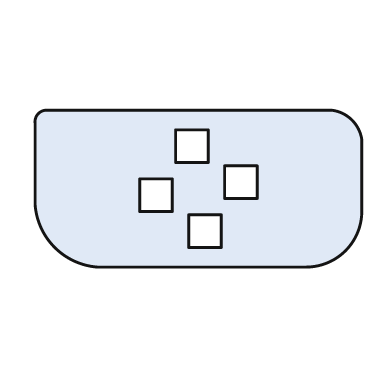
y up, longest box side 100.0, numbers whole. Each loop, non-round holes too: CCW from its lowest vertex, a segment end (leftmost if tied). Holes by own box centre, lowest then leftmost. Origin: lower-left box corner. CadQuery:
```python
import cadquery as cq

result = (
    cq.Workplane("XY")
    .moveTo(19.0, 0.0)
    .lineTo(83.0, 0.0)
    .threePointArc((95.0, 5.0), (100.0, 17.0))
    .lineTo(100.0, 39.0)
    .threePointArc((97.0, 45.0), (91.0, 48.0))
    .lineTo(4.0, 48.0)
    .threePointArc((1.0, 47.0), (0.0, 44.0))
    .lineTo(0.0, 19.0)
    .threePointArc((6.0, 6.0), (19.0, 0.0))
    .close()
    .moveTo(47.0, 6.0)
    .lineTo(57.0, 6.0)
    .lineTo(57.0, 16.0)
    .lineTo(47.0, 16.0)
    .close()
    .moveTo(32.0, 17.0)
    .lineTo(42.0, 17.0)
    .lineTo(42.0, 27.0)
    .lineTo(32.0, 27.0)
    .close()
    .moveTo(58.0, 21.0)
    .lineTo(68.0, 21.0)
    .lineTo(68.0, 31.0)
    .lineTo(58.0, 31.0)
    .close()
    .moveTo(43.0, 32.0)
    .lineTo(53.0, 32.0)
    .lineTo(53.0, 42.0)
    .lineTo(43.0, 42.0)
    .close()
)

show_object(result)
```